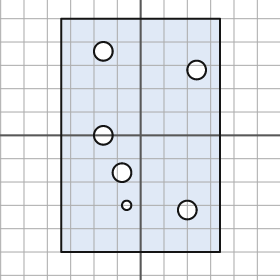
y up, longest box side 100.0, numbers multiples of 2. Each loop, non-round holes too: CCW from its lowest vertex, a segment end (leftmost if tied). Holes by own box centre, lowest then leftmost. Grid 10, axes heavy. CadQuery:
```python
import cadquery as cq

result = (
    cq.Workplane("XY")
    .moveTo(-34.0, -50.0)
    .lineTo(34.0, -50.0)
    .lineTo(34.0, 50.0)
    .lineTo(-34.0, 50.0)
    .close()
    .moveTo(20.0, -32.0)
    .circle(4.0)
    .moveTo(-6.0, -30.0)
    .circle(2.0)
    .moveTo(-8.0, -16.0)
    .circle(4.0)
    .moveTo(-16.0, 0.0)
    .circle(4.0)
    .moveTo(24.0, 28.0)
    .circle(4.0)
    .moveTo(-16.0, 36.0)
    .circle(4.0)
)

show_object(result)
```